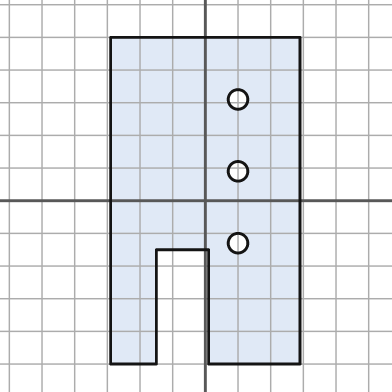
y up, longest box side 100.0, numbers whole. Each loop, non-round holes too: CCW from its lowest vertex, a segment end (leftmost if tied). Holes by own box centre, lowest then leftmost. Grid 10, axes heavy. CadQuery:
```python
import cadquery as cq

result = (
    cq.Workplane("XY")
    .moveTo(-29.0, -50.0)
    .lineTo(-15.0, -50.0)
    .lineTo(-15.0, -15.0)
    .lineTo(1.0, -15.0)
    .lineTo(1.0, -50.0)
    .lineTo(29.0, -50.0)
    .lineTo(29.0, 50.0)
    .lineTo(-29.0, 50.0)
    .close()
    .moveTo(10.0, -13.0)
    .circle(3.0)
    .moveTo(10.0, 9.0)
    .circle(3.0)
    .moveTo(10.0, 31.0)
    .circle(3.0)
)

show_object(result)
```